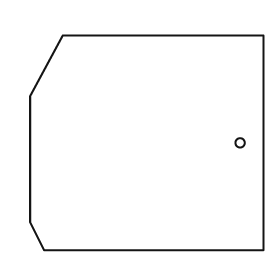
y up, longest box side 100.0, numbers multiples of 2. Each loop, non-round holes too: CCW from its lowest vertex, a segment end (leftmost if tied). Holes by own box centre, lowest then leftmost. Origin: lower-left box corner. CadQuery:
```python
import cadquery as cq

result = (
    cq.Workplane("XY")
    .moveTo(6.0, 0.0)
    .lineTo(100.0, 0.0)
    .lineTo(100.0, 92.0)
    .lineTo(14.0, 92.0)
    .lineTo(0.0, 66.0)
    .lineTo(0.0, 12.0)
    .close()
    .moveTo(90.0, 46.0)
    .circle(2.0)
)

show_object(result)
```